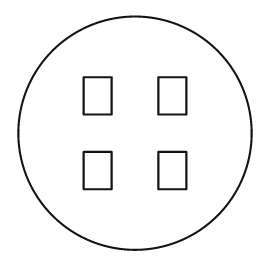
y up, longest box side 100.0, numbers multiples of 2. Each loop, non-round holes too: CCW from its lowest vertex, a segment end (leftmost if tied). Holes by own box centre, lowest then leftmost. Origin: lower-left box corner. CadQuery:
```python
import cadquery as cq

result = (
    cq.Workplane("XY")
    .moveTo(50.0, 50.0)
    .circle(50.0)
    .moveTo(28.0, 26.0)
    .lineTo(40.0, 26.0)
    .lineTo(40.0, 42.0)
    .lineTo(28.0, 42.0)
    .close()
    .moveTo(60.0, 26.0)
    .lineTo(72.0, 26.0)
    .lineTo(72.0, 42.0)
    .lineTo(60.0, 42.0)
    .close()
    .moveTo(28.0, 58.0)
    .lineTo(40.0, 58.0)
    .lineTo(40.0, 74.0)
    .lineTo(28.0, 74.0)
    .close()
    .moveTo(60.0, 58.0)
    .lineTo(72.0, 58.0)
    .lineTo(72.0, 74.0)
    .lineTo(60.0, 74.0)
    .close()
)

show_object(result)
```